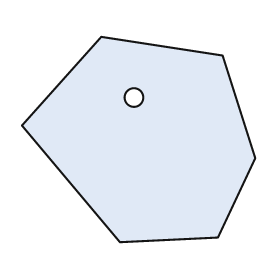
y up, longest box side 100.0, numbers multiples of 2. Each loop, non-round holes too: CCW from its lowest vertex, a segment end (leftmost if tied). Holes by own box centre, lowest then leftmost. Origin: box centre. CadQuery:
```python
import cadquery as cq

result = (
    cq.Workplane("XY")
    .moveTo(-8.0, -44.0)
    .lineTo(34.0, -42.0)
    .lineTo(50.0, -8.0)
    .lineTo(36.0, 36.0)
    .lineTo(-16.0, 44.0)
    .lineTo(-50.0, 6.0)
    .close()
    .moveTo(-2.0, 18.0)
    .circle(4.0)
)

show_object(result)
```